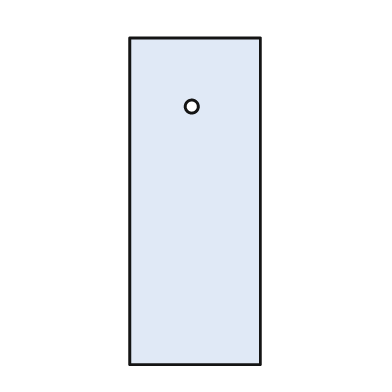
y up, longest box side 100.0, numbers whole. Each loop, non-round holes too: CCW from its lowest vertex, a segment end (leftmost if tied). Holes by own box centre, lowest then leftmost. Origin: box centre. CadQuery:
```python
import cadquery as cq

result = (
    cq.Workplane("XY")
    .moveTo(-20.0, -50.0)
    .lineTo(20.0, -50.0)
    .lineTo(20.0, 50.0)
    .lineTo(-20.0, 50.0)
    .close()
    .moveTo(-1.0, 29.0)
    .circle(2.0)
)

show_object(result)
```